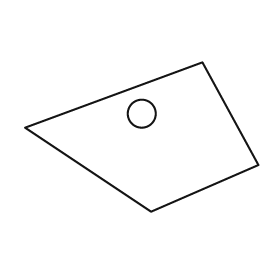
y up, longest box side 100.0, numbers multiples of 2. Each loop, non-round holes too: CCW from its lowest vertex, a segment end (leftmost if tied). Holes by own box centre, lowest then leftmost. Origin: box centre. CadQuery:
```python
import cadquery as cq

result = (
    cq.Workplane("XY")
    .moveTo(4.0, -32.0)
    .lineTo(50.0, -12.0)
    .lineTo(26.0, 32.0)
    .lineTo(-50.0, 4.0)
    .close()
    .moveTo(0.0, 10.0)
    .circle(6.0)
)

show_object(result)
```